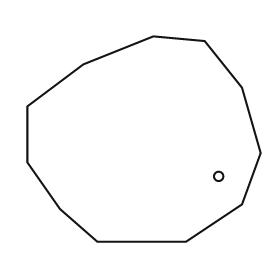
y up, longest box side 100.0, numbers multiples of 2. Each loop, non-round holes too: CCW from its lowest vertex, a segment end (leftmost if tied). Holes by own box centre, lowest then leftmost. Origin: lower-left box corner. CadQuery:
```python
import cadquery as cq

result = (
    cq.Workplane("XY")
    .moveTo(30.0, 0.0)
    .lineTo(68.0, 0.0)
    .lineTo(92.0, 16.0)
    .lineTo(100.0, 38.0)
    .lineTo(92.0, 66.0)
    .lineTo(76.0, 86.0)
    .lineTo(54.0, 88.0)
    .lineTo(24.0, 76.0)
    .lineTo(0.0, 58.0)
    .lineTo(0.0, 34.0)
    .lineTo(14.0, 14.0)
    .close()
    .moveTo(82.0, 28.0)
    .circle(2.0)
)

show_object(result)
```